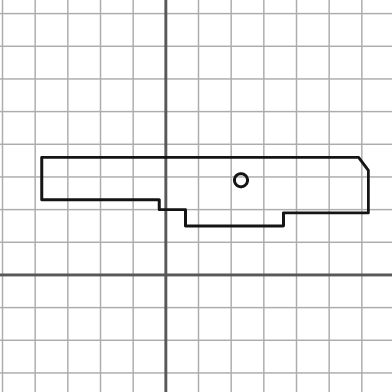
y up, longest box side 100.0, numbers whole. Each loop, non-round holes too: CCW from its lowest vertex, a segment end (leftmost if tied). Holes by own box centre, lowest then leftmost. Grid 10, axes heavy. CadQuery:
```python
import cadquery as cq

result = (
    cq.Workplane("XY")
    .moveTo(6.0, 15.0)
    .lineTo(36.0, 15.0)
    .lineTo(36.0, 19.0)
    .lineTo(62.0, 19.0)
    .lineTo(62.0, 32.0)
    .lineTo(59.0, 36.0)
    .lineTo(-38.0, 36.0)
    .lineTo(-38.0, 23.0)
    .lineTo(-2.0, 23.0)
    .lineTo(-2.0, 20.0)
    .lineTo(6.0, 20.0)
    .close()
    .moveTo(23.0, 29.0)
    .circle(2.0)
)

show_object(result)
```